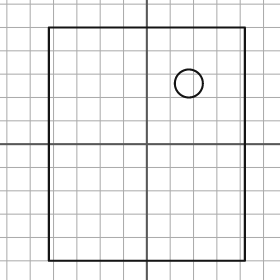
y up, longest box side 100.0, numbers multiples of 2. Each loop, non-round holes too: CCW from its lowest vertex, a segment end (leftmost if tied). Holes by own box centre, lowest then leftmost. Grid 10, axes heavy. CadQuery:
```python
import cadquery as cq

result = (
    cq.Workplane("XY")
    .moveTo(-42.0, -50.0)
    .lineTo(42.0, -50.0)
    .lineTo(42.0, 50.0)
    .lineTo(-42.0, 50.0)
    .close()
    .moveTo(18.0, 26.0)
    .circle(6.0)
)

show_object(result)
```